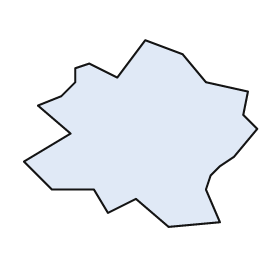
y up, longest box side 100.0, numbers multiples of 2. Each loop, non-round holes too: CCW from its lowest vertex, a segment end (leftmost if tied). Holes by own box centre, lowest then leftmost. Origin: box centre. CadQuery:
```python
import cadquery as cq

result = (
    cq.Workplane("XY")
    .moveTo(12.0, -40.0)
    .lineTo(34.0, -38.0)
    .lineTo(28.0, -24.0)
    .lineTo(30.0, -18.0)
    .lineTo(34.0, -14.0)
    .lineTo(40.0, -10.0)
    .lineTo(50.0, 2.0)
    .lineTo(44.0, 8.0)
    .lineTo(46.0, 18.0)
    .lineTo(28.0, 22.0)
    .lineTo(18.0, 34.0)
    .lineTo(2.0, 40.0)
    .lineTo(-10.0, 24.0)
    .lineTo(-22.0, 30.0)
    .lineTo(-28.0, 28.0)
    .lineTo(-28.0, 22.0)
    .lineTo(-34.0, 16.0)
    .lineTo(-44.0, 12.0)
    .lineTo(-30.0, 0.0)
    .lineTo(-50.0, -12.0)
    .lineTo(-38.0, -24.0)
    .lineTo(-20.0, -24.0)
    .lineTo(-14.0, -34.0)
    .lineTo(-2.0, -28.0)
    .close()
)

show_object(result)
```